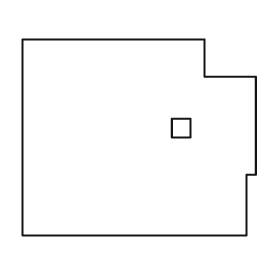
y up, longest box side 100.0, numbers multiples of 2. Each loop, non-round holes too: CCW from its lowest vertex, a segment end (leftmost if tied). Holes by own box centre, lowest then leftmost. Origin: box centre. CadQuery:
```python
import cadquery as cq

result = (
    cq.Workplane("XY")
    .moveTo(-50.0, -42.0)
    .lineTo(46.0, -42.0)
    .lineTo(46.0, -16.0)
    .lineTo(50.0, -16.0)
    .lineTo(50.0, 26.0)
    .lineTo(28.0, 26.0)
    .lineTo(28.0, 42.0)
    .lineTo(-50.0, 42.0)
    .close()
    .moveTo(14.0, 0.0)
    .lineTo(22.0, 0.0)
    .lineTo(22.0, 8.0)
    .lineTo(14.0, 8.0)
    .close()
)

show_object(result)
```